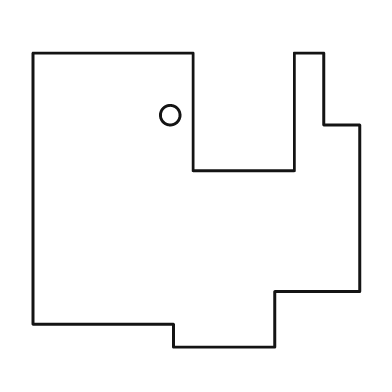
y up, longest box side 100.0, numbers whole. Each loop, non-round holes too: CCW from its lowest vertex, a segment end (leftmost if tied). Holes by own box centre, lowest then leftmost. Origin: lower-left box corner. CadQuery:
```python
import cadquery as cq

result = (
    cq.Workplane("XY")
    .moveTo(43.0, 0.0)
    .lineTo(74.0, 0.0)
    .lineTo(74.0, 17.0)
    .lineTo(100.0, 17.0)
    .lineTo(100.0, 68.0)
    .lineTo(89.0, 68.0)
    .lineTo(89.0, 90.0)
    .lineTo(80.0, 90.0)
    .lineTo(80.0, 54.0)
    .lineTo(49.0, 54.0)
    .lineTo(49.0, 90.0)
    .lineTo(0.0, 90.0)
    .lineTo(0.0, 7.0)
    .lineTo(43.0, 7.0)
    .close()
    .moveTo(42.0, 71.0)
    .circle(3.0)
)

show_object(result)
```